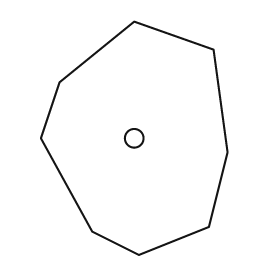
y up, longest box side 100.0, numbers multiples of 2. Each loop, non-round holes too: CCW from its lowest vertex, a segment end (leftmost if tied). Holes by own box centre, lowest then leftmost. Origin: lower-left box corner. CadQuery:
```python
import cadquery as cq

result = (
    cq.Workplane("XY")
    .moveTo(42.0, 0.0)
    .lineTo(72.0, 12.0)
    .lineTo(80.0, 44.0)
    .lineTo(74.0, 88.0)
    .lineTo(40.0, 100.0)
    .lineTo(8.0, 74.0)
    .lineTo(0.0, 50.0)
    .lineTo(22.0, 10.0)
    .close()
    .moveTo(40.0, 50.0)
    .circle(4.0)
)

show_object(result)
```